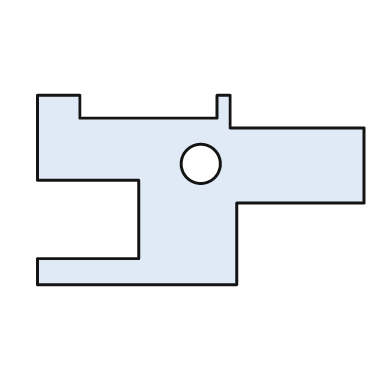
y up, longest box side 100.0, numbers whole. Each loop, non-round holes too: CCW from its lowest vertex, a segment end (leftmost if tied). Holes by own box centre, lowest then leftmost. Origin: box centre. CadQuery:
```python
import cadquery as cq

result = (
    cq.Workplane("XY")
    .moveTo(-50.0, -29.0)
    .lineTo(11.0, -29.0)
    .lineTo(11.0, -4.0)
    .lineTo(50.0, -4.0)
    .lineTo(50.0, 19.0)
    .lineTo(9.0, 19.0)
    .lineTo(9.0, 29.0)
    .lineTo(5.0, 29.0)
    .lineTo(5.0, 22.0)
    .lineTo(-37.0, 22.0)
    .lineTo(-37.0, 29.0)
    .lineTo(-50.0, 29.0)
    .lineTo(-50.0, 3.0)
    .lineTo(-19.0, 3.0)
    .lineTo(-19.0, -21.0)
    .lineTo(-50.0, -21.0)
    .close()
    .moveTo(0.0, 8.0)
    .circle(6.0)
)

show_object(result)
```